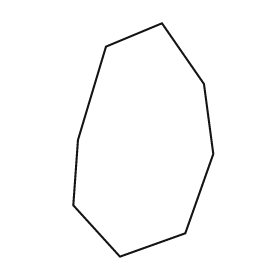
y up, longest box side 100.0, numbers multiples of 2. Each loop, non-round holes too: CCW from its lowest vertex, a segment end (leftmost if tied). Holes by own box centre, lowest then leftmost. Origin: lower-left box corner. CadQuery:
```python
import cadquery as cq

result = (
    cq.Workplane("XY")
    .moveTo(20.0, 0.0)
    .lineTo(48.0, 10.0)
    .lineTo(60.0, 44.0)
    .lineTo(56.0, 74.0)
    .lineTo(38.0, 100.0)
    .lineTo(14.0, 90.0)
    .lineTo(2.0, 50.0)
    .lineTo(0.0, 22.0)
    .close()
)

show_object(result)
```